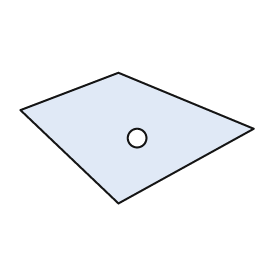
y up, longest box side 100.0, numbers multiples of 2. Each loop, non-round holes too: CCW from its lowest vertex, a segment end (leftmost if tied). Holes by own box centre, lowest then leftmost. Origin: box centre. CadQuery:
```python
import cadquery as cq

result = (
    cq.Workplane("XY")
    .moveTo(-8.0, -28.0)
    .lineTo(50.0, 4.0)
    .lineTo(-8.0, 28.0)
    .lineTo(-50.0, 12.0)
    .close()
    .moveTo(0.0, 0.0)
    .circle(4.0)
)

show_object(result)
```